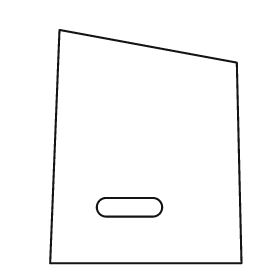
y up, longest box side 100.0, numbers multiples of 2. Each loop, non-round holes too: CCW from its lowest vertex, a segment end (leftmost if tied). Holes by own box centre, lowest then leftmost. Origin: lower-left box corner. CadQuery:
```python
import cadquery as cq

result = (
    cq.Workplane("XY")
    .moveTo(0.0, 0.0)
    .lineTo(82.0, 0.0)
    .lineTo(80.0, 86.0)
    .lineTo(4.0, 100.0)
    .close()
    .moveTo(24.0, 20.0)
    .lineTo(44.0, 20.0)
    .threePointArc((48.0, 24.0), (44.0, 28.0))
    .lineTo(24.0, 28.0)
    .threePointArc((20.0, 24.0), (24.0, 20.0))
    .close()
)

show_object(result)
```